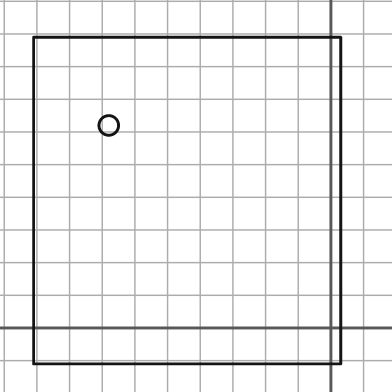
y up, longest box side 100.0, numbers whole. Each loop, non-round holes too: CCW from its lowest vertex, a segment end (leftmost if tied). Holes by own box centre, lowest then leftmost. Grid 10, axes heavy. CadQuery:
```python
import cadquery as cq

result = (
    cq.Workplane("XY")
    .moveTo(-91.0, -11.0)
    .lineTo(3.0, -11.0)
    .lineTo(3.0, 89.0)
    .lineTo(-91.0, 89.0)
    .close()
    .moveTo(-68.0, 62.0)
    .circle(3.0)
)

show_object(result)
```